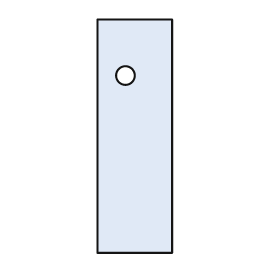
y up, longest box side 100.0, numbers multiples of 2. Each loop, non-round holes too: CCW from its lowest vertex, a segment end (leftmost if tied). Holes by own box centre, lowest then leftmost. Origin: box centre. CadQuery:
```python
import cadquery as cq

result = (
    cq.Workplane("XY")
    .moveTo(-16.0, -50.0)
    .lineTo(16.0, -50.0)
    .lineTo(16.0, 50.0)
    .lineTo(-16.0, 50.0)
    .close()
    .moveTo(-4.0, 26.0)
    .circle(4.0)
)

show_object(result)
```